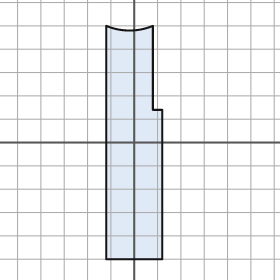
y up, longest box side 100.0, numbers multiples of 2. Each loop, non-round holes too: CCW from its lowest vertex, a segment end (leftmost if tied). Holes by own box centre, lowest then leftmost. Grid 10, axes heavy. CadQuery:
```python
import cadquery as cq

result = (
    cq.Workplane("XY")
    .moveTo(-12.0, -50.0)
    .lineTo(12.0, -50.0)
    .lineTo(12.0, 14.0)
    .lineTo(8.0, 14.0)
    .lineTo(8.0, 50.0)
    .threePointArc((-2.0, 48.0), (-12.0, 50.0))
    .close()
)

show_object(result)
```